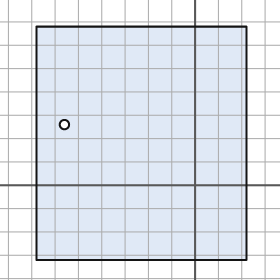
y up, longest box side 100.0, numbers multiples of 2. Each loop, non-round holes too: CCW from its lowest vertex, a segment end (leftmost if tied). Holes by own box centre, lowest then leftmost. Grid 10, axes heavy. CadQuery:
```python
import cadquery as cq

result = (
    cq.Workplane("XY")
    .moveTo(-68.0, -32.0)
    .lineTo(22.0, -32.0)
    .lineTo(22.0, 68.0)
    .lineTo(-68.0, 68.0)
    .close()
    .moveTo(-56.0, 26.0)
    .circle(2.0)
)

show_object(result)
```